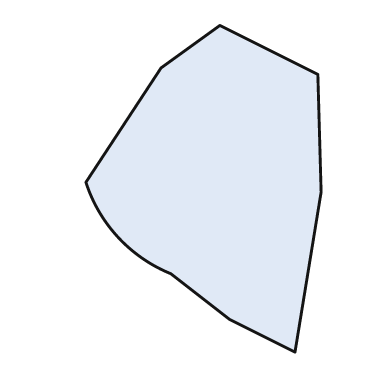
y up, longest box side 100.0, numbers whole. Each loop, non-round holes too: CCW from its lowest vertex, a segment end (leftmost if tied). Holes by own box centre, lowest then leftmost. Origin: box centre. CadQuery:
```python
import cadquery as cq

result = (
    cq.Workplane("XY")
    .moveTo(28.0, -50.0)
    .lineTo(36.0, -1.0)
    .lineTo(35.0, 35.0)
    .lineTo(5.0, 50.0)
    .lineTo(-13.0, 37.0)
    .lineTo(-36.0, 2.0)
    .threePointArc((-26.0, -15.0), (-10.0, -26.0))
    .lineTo(8.0, -40.0)
    .close()
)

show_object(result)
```